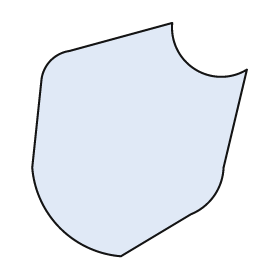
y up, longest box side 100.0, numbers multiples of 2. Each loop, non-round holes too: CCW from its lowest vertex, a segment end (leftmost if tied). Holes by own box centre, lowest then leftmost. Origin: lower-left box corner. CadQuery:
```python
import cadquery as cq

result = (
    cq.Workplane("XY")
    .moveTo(38.0, 0.0)
    .lineTo(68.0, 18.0)
    .threePointArc((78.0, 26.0), (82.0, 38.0))
    .lineTo(92.0, 80.0)
    .threePointArc((70.0, 80.0), (60.0, 100.0))
    .lineTo(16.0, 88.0)
    .threePointArc((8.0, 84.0), (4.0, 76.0))
    .lineTo(0.0, 38.0)
    .threePointArc((12.0, 12.0), (38.0, 0.0))
    .close()
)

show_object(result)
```